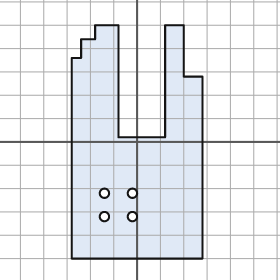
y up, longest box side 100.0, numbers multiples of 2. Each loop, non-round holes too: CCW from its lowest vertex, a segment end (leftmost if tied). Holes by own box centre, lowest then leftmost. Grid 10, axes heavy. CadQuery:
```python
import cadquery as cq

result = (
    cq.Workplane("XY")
    .moveTo(-28.0, -50.0)
    .lineTo(28.0, -50.0)
    .lineTo(28.0, 28.0)
    .lineTo(20.0, 28.0)
    .lineTo(20.0, 50.0)
    .lineTo(12.0, 50.0)
    .lineTo(12.0, 2.0)
    .lineTo(-8.0, 2.0)
    .lineTo(-8.0, 50.0)
    .lineTo(-18.0, 50.0)
    .lineTo(-18.0, 44.0)
    .lineTo(-24.0, 44.0)
    .lineTo(-24.0, 36.0)
    .lineTo(-28.0, 36.0)
    .close()
    .moveTo(-14.0, -32.0)
    .circle(2.0)
    .moveTo(-2.0, -32.0)
    .circle(2.0)
    .moveTo(-14.0, -22.0)
    .circle(2.0)
    .moveTo(-2.0, -22.0)
    .circle(2.0)
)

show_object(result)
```